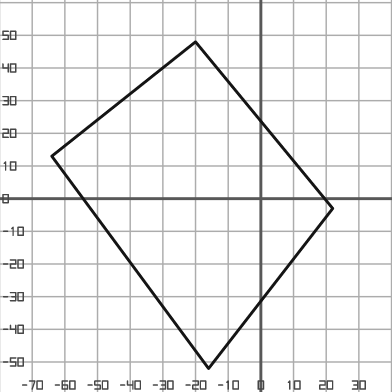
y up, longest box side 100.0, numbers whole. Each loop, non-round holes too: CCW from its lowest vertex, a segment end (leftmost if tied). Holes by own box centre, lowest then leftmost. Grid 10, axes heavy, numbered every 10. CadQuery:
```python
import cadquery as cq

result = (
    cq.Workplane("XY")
    .moveTo(-16.0, -52.0)
    .lineTo(22.0, -3.0)
    .lineTo(-20.0, 48.0)
    .lineTo(-64.0, 13.0)
    .close()
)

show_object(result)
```